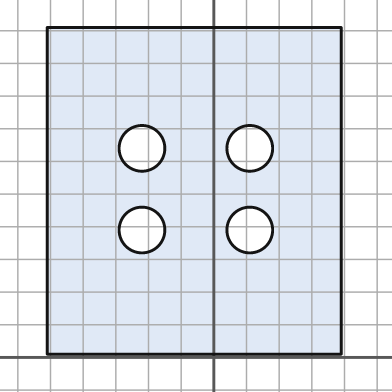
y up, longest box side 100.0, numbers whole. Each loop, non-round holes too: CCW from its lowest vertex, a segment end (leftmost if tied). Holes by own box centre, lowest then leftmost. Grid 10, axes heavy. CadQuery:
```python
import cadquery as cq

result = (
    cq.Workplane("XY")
    .moveTo(-51.0, 1.0)
    .lineTo(39.0, 1.0)
    .lineTo(39.0, 101.0)
    .lineTo(-51.0, 101.0)
    .close()
    .moveTo(-22.0, 39.0)
    .circle(7.0)
    .moveTo(11.0, 39.0)
    .circle(7.0)
    .moveTo(-22.0, 64.0)
    .circle(7.0)
    .moveTo(11.0, 64.0)
    .circle(7.0)
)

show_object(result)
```